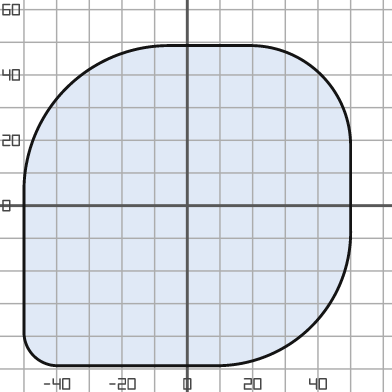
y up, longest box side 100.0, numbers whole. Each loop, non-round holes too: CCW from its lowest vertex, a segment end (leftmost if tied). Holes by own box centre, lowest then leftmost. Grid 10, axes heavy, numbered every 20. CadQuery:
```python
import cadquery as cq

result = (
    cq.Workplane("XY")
    .moveTo(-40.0, -49.0)
    .lineTo(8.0, -49.0)
    .threePointArc((38.0, -37.0), (50.0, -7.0))
    .lineTo(50.0, 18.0)
    .threePointArc((41.0, 40.0), (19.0, 49.0))
    .lineTo(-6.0, 49.0)
    .threePointArc((-37.0, 36.0), (-50.0, 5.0))
    .lineTo(-50.0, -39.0)
    .threePointArc((-47.0, -46.0), (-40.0, -49.0))
    .close()
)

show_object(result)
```